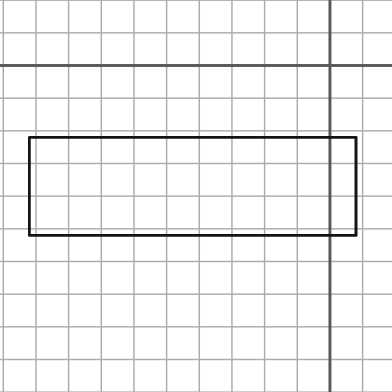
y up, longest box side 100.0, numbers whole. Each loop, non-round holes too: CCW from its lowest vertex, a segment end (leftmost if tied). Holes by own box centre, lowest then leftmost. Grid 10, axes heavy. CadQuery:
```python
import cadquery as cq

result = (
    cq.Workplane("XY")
    .moveTo(-92.0, -52.0)
    .lineTo(8.0, -52.0)
    .lineTo(8.0, -22.0)
    .lineTo(-92.0, -22.0)
    .close()
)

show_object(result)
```